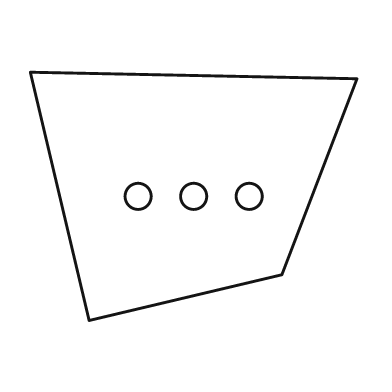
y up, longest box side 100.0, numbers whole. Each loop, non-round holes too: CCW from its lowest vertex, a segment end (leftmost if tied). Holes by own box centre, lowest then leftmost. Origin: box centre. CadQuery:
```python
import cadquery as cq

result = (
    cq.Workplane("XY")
    .moveTo(-32.0, -38.0)
    .lineTo(27.0, -24.0)
    .lineTo(50.0, 36.0)
    .lineTo(-50.0, 38.0)
    .close()
    .moveTo(-17.0, 0.0)
    .circle(4.0)
    .moveTo(0.0, 0.0)
    .circle(4.0)
    .moveTo(17.0, 0.0)
    .circle(4.0)
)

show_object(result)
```